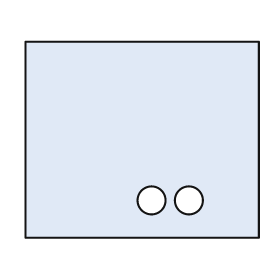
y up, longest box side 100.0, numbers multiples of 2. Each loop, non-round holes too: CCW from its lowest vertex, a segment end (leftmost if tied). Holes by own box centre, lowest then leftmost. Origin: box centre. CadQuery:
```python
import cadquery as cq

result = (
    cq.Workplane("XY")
    .moveTo(-50.0, -42.0)
    .lineTo(50.0, -42.0)
    .lineTo(50.0, 42.0)
    .lineTo(-50.0, 42.0)
    .close()
    .moveTo(4.0, -26.0)
    .circle(6.0)
    .moveTo(20.0, -26.0)
    .circle(6.0)
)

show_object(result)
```